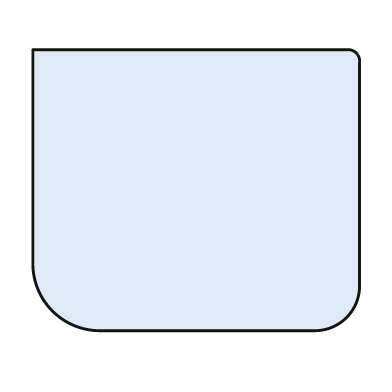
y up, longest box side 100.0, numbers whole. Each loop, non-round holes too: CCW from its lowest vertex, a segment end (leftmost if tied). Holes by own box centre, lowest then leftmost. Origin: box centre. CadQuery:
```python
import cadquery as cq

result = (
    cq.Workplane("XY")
    .moveTo(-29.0, -43.0)
    .lineTo(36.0, -43.0)
    .threePointArc((46.0, -39.0), (50.0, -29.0))
    .lineTo(50.0, 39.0)
    .threePointArc((49.0, 42.0), (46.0, 43.0))
    .lineTo(-50.0, 43.0)
    .lineTo(-50.0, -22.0)
    .threePointArc((-44.0, -37.0), (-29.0, -43.0))
    .close()
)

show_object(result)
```